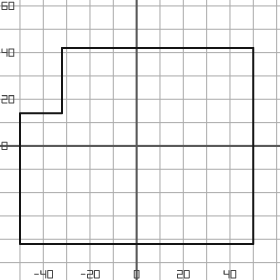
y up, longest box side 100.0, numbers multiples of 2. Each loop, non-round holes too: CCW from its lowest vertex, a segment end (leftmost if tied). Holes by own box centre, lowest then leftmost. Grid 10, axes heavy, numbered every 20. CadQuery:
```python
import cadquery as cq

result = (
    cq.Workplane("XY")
    .moveTo(-50.0, -42.0)
    .lineTo(50.0, -42.0)
    .lineTo(50.0, 42.0)
    .lineTo(-32.0, 42.0)
    .lineTo(-32.0, 14.0)
    .lineTo(-50.0, 14.0)
    .close()
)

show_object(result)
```